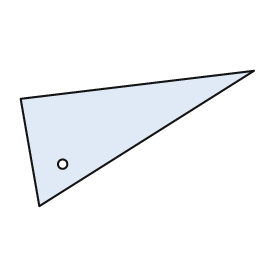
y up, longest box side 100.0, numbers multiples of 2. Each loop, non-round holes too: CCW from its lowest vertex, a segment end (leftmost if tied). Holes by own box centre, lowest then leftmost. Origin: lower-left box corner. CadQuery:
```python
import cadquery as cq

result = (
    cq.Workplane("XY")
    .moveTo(8.0, 0.0)
    .lineTo(100.0, 58.0)
    .lineTo(0.0, 46.0)
    .close()
    .moveTo(18.0, 18.0)
    .circle(2.0)
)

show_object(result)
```